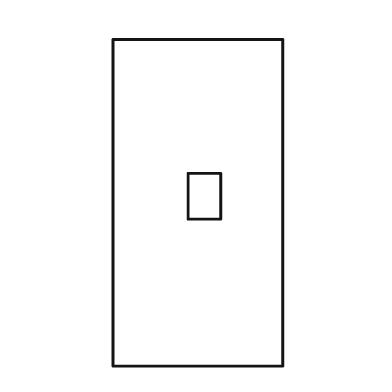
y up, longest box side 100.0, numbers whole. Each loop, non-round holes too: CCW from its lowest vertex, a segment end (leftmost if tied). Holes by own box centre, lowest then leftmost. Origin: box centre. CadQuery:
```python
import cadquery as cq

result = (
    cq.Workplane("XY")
    .moveTo(-26.0, -50.0)
    .lineTo(26.0, -50.0)
    .lineTo(26.0, 50.0)
    .lineTo(-26.0, 50.0)
    .close()
    .moveTo(-3.0, -5.0)
    .lineTo(7.0, -5.0)
    .lineTo(7.0, 9.0)
    .lineTo(-3.0, 9.0)
    .close()
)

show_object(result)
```